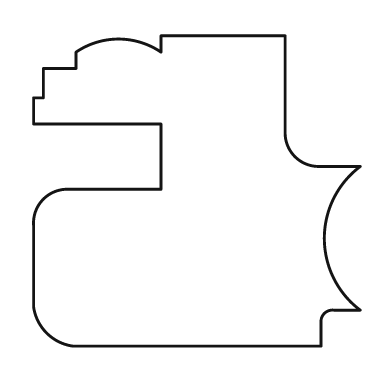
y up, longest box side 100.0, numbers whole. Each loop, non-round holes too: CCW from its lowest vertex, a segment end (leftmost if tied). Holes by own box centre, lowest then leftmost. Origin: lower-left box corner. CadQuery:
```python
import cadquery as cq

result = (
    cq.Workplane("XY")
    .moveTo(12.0, 0.0)
    .lineTo(88.0, 0.0)
    .lineTo(88.0, 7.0)
    .threePointArc((89.0, 10.0), (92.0, 11.0))
    .lineTo(100.0, 11.0)
    .threePointArc((89.0, 33.0), (100.0, 55.0))
    .lineTo(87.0, 55.0)
    .threePointArc((80.0, 58.0), (77.0, 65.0))
    .lineTo(77.0, 95.0)
    .lineTo(39.0, 95.0)
    .lineTo(39.0, 90.0)
    .threePointArc((26.0, 94.0), (13.0, 90.0))
    .lineTo(13.0, 85.0)
    .lineTo(3.0, 85.0)
    .lineTo(3.0, 76.0)
    .lineTo(0.0, 76.0)
    .lineTo(0.0, 68.0)
    .lineTo(39.0, 68.0)
    .lineTo(39.0, 48.0)
    .lineTo(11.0, 48.0)
    .threePointArc((3.0, 45.0), (0.0, 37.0))
    .lineTo(0.0, 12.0)
    .threePointArc((4.0, 4.0), (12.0, 0.0))
    .close()
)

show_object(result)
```